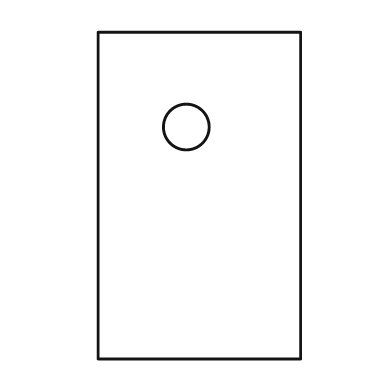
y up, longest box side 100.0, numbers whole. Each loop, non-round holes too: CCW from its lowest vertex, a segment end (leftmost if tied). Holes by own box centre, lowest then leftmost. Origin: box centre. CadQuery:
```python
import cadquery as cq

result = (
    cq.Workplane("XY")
    .moveTo(-31.0, -50.0)
    .lineTo(31.0, -50.0)
    .lineTo(31.0, 50.0)
    .lineTo(-31.0, 50.0)
    .close()
    .moveTo(-4.0, 21.0)
    .circle(7.0)
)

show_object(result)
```